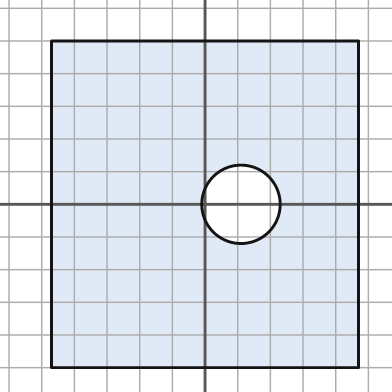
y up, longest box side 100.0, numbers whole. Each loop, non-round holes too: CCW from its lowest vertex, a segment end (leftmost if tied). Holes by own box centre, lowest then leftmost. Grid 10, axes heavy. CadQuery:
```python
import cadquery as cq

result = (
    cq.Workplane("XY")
    .moveTo(-47.0, -50.0)
    .lineTo(47.0, -50.0)
    .lineTo(47.0, 50.0)
    .lineTo(-47.0, 50.0)
    .close()
    .moveTo(11.0, 0.0)
    .circle(12.0)
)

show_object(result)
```